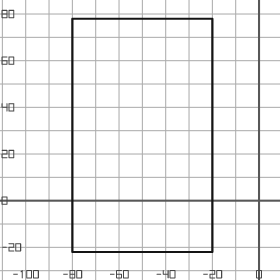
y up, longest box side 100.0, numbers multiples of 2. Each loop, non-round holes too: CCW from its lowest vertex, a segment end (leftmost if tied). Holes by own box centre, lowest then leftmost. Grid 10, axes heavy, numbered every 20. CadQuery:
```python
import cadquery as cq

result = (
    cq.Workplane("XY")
    .moveTo(-80.0, -22.0)
    .lineTo(-20.0, -22.0)
    .lineTo(-20.0, 78.0)
    .lineTo(-80.0, 78.0)
    .close()
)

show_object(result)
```